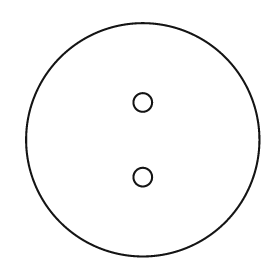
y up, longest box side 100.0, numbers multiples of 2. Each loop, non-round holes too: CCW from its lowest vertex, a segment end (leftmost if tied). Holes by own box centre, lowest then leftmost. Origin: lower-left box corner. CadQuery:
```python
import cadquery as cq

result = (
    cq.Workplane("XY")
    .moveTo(50.0, 50.0)
    .circle(50.0)
    .moveTo(50.0, 34.0)
    .circle(4.0)
    .moveTo(50.0, 66.0)
    .circle(4.0)
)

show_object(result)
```